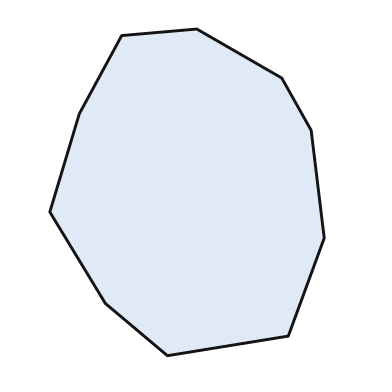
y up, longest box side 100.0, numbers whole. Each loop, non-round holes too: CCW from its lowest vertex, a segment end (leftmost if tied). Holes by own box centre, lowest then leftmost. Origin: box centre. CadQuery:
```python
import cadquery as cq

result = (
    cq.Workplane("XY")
    .moveTo(-6.0, -50.0)
    .lineTo(31.0, -44.0)
    .lineTo(42.0, -14.0)
    .lineTo(38.0, 19.0)
    .lineTo(29.0, 35.0)
    .lineTo(3.0, 50.0)
    .lineTo(-20.0, 48.0)
    .lineTo(-33.0, 24.0)
    .lineTo(-42.0, -6.0)
    .lineTo(-25.0, -34.0)
    .close()
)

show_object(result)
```